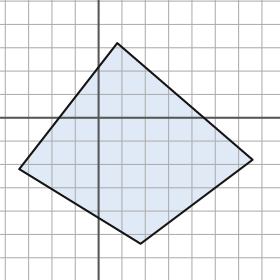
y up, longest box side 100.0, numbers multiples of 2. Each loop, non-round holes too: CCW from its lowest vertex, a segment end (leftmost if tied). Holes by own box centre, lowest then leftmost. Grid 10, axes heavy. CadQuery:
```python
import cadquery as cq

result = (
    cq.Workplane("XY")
    .moveTo(18.0, -54.0)
    .lineTo(66.0, -18.0)
    .lineTo(8.0, 32.0)
    .lineTo(-34.0, -22.0)
    .close()
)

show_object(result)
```